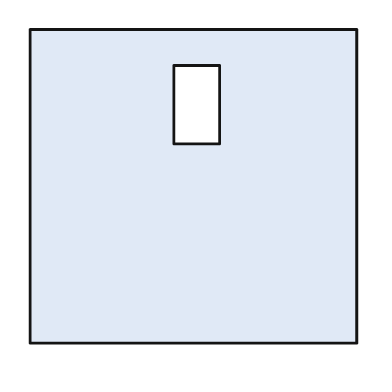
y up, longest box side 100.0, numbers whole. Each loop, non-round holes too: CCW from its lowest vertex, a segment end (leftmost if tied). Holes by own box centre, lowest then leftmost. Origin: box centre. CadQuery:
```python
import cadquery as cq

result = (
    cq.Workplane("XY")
    .moveTo(-50.0, -48.0)
    .lineTo(50.0, -48.0)
    .lineTo(50.0, 48.0)
    .lineTo(-50.0, 48.0)
    .close()
    .moveTo(-6.0, 13.0)
    .lineTo(8.0, 13.0)
    .lineTo(8.0, 37.0)
    .lineTo(-6.0, 37.0)
    .close()
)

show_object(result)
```